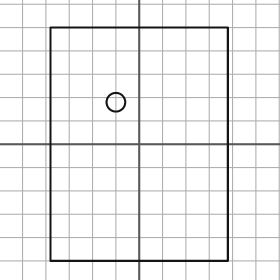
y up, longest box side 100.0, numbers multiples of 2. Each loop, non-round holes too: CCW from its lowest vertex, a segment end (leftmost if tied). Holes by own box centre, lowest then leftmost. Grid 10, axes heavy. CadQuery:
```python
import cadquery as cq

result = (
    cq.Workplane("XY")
    .moveTo(-38.0, -50.0)
    .lineTo(38.0, -50.0)
    .lineTo(38.0, 50.0)
    .lineTo(-38.0, 50.0)
    .close()
    .moveTo(-10.0, 18.0)
    .circle(4.0)
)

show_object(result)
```